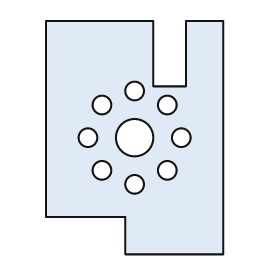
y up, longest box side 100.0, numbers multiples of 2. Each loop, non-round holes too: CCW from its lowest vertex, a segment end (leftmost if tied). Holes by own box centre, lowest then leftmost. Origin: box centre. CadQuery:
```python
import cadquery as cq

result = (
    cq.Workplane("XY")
    .moveTo(-4.0, -50.0)
    .lineTo(38.0, -50.0)
    .lineTo(38.0, 50.0)
    .lineTo(22.0, 50.0)
    .lineTo(22.0, 22.0)
    .lineTo(8.0, 22.0)
    .lineTo(8.0, 50.0)
    .lineTo(-38.0, 50.0)
    .lineTo(-38.0, -34.0)
    .lineTo(-4.0, -34.0)
    .close()
    .moveTo(0.0, -20.0)
    .circle(4.0)
    .moveTo(-14.0, -14.0)
    .circle(4.0)
    .moveTo(14.0, -14.0)
    .circle(4.0)
    .moveTo(-20.0, 0.0)
    .circle(4.0)
    .moveTo(0.0, 0.0)
    .circle(8.0)
    .moveTo(20.0, 0.0)
    .circle(4.0)
    .moveTo(-14.0, 14.0)
    .circle(4.0)
    .moveTo(14.0, 14.0)
    .circle(4.0)
    .moveTo(0.0, 20.0)
    .circle(4.0)
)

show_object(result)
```